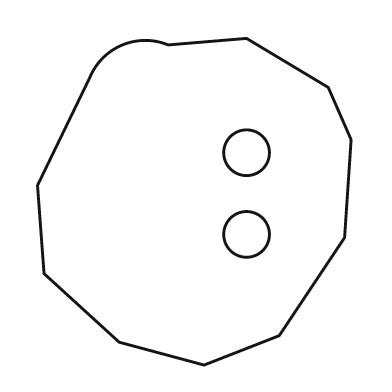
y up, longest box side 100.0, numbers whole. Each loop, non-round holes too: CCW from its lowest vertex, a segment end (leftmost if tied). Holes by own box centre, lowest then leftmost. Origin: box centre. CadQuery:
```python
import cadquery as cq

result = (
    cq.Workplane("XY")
    .moveTo(3.0, -50.0)
    .lineTo(26.0, -41.0)
    .lineTo(46.0, -11.0)
    .lineTo(48.0, 19.0)
    .lineTo(41.0, 35.0)
    .lineTo(16.0, 50.0)
    .lineTo(-8.0, 48.0)
    .threePointArc((-22.0, 48.0), (-32.0, 38.0))
    .lineTo(-48.0, 5.0)
    .lineTo(-46.0, -22.0)
    .lineTo(-23.0, -43.0)
    .close()
    .moveTo(16.0, -10.0)
    .circle(7.0)
    .moveTo(16.0, 15.0)
    .circle(7.0)
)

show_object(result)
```